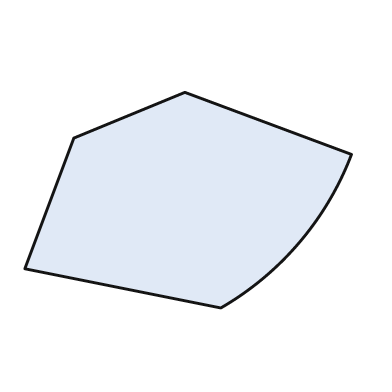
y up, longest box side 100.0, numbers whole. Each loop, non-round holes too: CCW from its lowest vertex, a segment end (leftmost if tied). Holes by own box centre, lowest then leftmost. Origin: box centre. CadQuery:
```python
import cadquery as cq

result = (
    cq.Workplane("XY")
    .moveTo(10.0, -33.0)
    .threePointArc((34.0, -13.0), (50.0, 14.0))
    .lineTo(-1.0, 33.0)
    .lineTo(-35.0, 19.0)
    .lineTo(-50.0, -21.0)
    .close()
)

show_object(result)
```